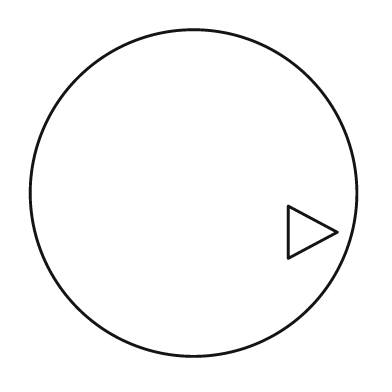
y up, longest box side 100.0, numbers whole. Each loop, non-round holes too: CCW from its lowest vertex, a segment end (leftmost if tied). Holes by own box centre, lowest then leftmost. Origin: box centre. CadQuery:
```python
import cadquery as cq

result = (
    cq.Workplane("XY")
    .moveTo(0.0, 0.0)
    .circle(50.0)
    .moveTo(29.0, -20.0)
    .lineTo(44.0, -12.0)
    .lineTo(29.0, -4.0)
    .close()
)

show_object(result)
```